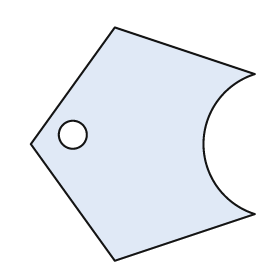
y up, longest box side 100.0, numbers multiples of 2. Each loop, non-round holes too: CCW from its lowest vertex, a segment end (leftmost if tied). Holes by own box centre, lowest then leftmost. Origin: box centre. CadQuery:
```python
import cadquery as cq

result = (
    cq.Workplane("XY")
    .moveTo(-12.0, -50.0)
    .lineTo(48.0, -30.0)
    .threePointArc((26.0, 0.0), (48.0, 30.0))
    .lineTo(-12.0, 50.0)
    .lineTo(-48.0, 0.0)
    .close()
    .moveTo(-30.0, 4.0)
    .circle(6.0)
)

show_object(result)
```